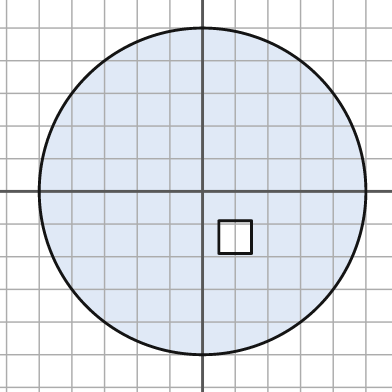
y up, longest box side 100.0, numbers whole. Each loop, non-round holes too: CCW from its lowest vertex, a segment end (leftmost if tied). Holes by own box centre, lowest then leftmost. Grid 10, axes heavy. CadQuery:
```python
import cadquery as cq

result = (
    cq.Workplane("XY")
    .moveTo(0.0, 0.0)
    .circle(50.0)
    .moveTo(5.0, -19.0)
    .lineTo(15.0, -19.0)
    .lineTo(15.0, -9.0)
    .lineTo(5.0, -9.0)
    .close()
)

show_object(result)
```